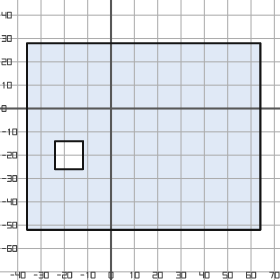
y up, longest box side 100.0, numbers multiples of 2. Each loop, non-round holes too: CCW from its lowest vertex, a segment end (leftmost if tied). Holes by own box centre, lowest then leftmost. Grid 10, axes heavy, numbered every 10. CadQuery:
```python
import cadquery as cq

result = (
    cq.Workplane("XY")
    .moveTo(-36.0, -52.0)
    .lineTo(64.0, -52.0)
    .lineTo(64.0, 28.0)
    .lineTo(-36.0, 28.0)
    .close()
    .moveTo(-24.0, -26.0)
    .lineTo(-12.0, -26.0)
    .lineTo(-12.0, -14.0)
    .lineTo(-24.0, -14.0)
    .close()
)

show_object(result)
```